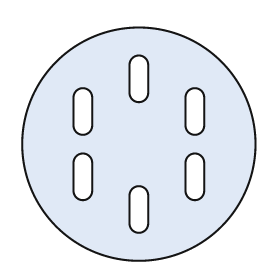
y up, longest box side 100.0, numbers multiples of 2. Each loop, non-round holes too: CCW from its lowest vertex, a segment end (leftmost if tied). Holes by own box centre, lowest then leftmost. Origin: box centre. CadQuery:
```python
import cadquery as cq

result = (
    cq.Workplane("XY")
    .moveTo(0.0, 0.0)
    .circle(50.0)
    .moveTo(-4.0, -34.0)
    .threePointArc((0.0, -38.0), (4.0, -34.0))
    .lineTo(4.0, -22.0)
    .threePointArc((0.0, -18.0), (-4.0, -22.0))
    .close()
    .moveTo(-28.0, -20.0)
    .threePointArc((-24.0, -24.0), (-20.0, -20.0))
    .lineTo(-20.0, -8.0)
    .threePointArc((-24.0, -4.0), (-28.0, -8.0))
    .close()
    .moveTo(20.0, -20.0)
    .threePointArc((24.0, -24.0), (28.0, -20.0))
    .lineTo(28.0, -8.0)
    .threePointArc((24.0, -4.0), (20.0, -8.0))
    .close()
    .moveTo(-28.0, 8.0)
    .threePointArc((-24.0, 4.0), (-20.0, 8.0))
    .lineTo(-20.0, 20.0)
    .threePointArc((-24.0, 24.0), (-28.0, 20.0))
    .close()
    .moveTo(20.0, 8.0)
    .threePointArc((24.0, 4.0), (28.0, 8.0))
    .lineTo(28.0, 20.0)
    .threePointArc((24.0, 24.0), (20.0, 20.0))
    .close()
    .moveTo(-4.0, 22.0)
    .threePointArc((0.0, 18.0), (4.0, 22.0))
    .lineTo(4.0, 34.0)
    .threePointArc((0.0, 38.0), (-4.0, 34.0))
    .close()
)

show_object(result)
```